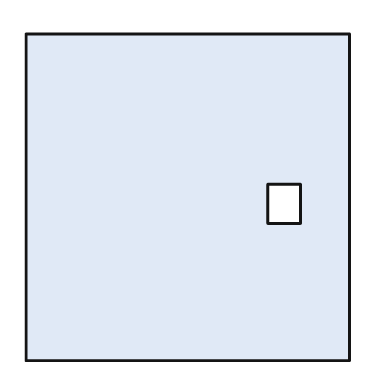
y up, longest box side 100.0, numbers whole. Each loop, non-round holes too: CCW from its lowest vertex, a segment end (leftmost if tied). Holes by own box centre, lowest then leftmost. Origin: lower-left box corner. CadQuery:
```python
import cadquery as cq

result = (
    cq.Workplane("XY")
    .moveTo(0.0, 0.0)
    .lineTo(99.0, 0.0)
    .lineTo(99.0, 100.0)
    .lineTo(0.0, 100.0)
    .close()
    .moveTo(74.0, 42.0)
    .lineTo(84.0, 42.0)
    .lineTo(84.0, 54.0)
    .lineTo(74.0, 54.0)
    .close()
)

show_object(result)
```